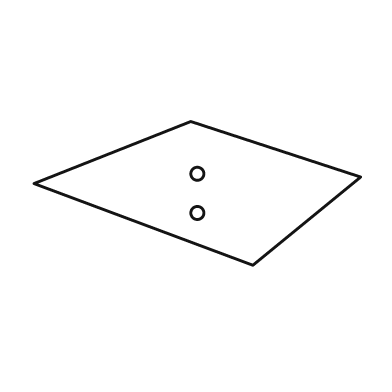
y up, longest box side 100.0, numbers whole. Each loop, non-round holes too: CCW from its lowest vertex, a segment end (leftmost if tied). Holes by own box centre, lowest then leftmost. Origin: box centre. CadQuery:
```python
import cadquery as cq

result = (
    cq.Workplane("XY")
    .moveTo(17.0, -22.0)
    .lineTo(50.0, 5.0)
    .lineTo(-2.0, 22.0)
    .lineTo(-50.0, 3.0)
    .close()
    .moveTo(0.0, -6.0)
    .circle(2.0)
    .moveTo(0.0, 6.0)
    .circle(2.0)
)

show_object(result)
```